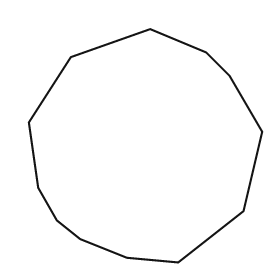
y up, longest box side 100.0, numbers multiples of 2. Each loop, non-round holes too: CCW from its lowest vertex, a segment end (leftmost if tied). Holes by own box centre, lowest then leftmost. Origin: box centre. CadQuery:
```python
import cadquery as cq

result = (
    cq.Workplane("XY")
    .moveTo(14.0, -50.0)
    .lineTo(42.0, -28.0)
    .lineTo(50.0, 6.0)
    .lineTo(36.0, 30.0)
    .lineTo(26.0, 40.0)
    .lineTo(2.0, 50.0)
    .lineTo(-32.0, 38.0)
    .lineTo(-50.0, 10.0)
    .lineTo(-46.0, -18.0)
    .lineTo(-38.0, -32.0)
    .lineTo(-28.0, -40.0)
    .lineTo(-8.0, -48.0)
    .close()
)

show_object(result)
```